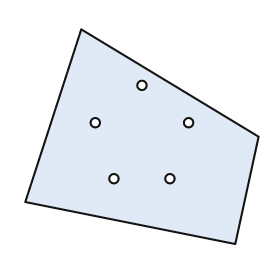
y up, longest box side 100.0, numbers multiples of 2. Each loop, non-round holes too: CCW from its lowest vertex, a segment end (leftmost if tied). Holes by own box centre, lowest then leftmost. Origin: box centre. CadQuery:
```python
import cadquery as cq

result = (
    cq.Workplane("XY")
    .moveTo(40.0, -46.0)
    .lineTo(50.0, 0.0)
    .lineTo(-26.0, 46.0)
    .lineTo(-50.0, -28.0)
    .close()
    .moveTo(-12.0, -18.0)
    .circle(2.0)
    .moveTo(12.0, -18.0)
    .circle(2.0)
    .moveTo(-20.0, 6.0)
    .circle(2.0)
    .moveTo(20.0, 6.0)
    .circle(2.0)
    .moveTo(0.0, 22.0)
    .circle(2.0)
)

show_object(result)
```